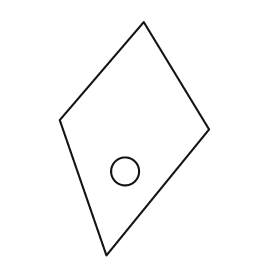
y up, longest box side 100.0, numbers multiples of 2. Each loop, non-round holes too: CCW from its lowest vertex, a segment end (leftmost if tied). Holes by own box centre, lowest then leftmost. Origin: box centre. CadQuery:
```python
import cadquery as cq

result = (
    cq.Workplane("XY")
    .moveTo(-12.0, -50.0)
    .lineTo(32.0, 4.0)
    .lineTo(4.0, 50.0)
    .lineTo(-32.0, 8.0)
    .close()
    .moveTo(-4.0, -14.0)
    .circle(6.0)
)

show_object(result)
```